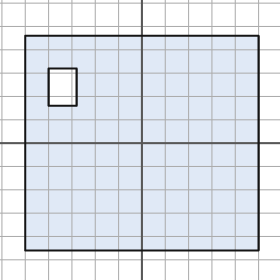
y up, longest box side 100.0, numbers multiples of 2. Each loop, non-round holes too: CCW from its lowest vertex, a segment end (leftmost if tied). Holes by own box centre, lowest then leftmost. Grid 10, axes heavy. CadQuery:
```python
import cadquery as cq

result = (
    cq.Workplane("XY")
    .moveTo(-50.0, -46.0)
    .lineTo(50.0, -46.0)
    .lineTo(50.0, 46.0)
    .lineTo(-50.0, 46.0)
    .close()
    .moveTo(-40.0, 16.0)
    .lineTo(-28.0, 16.0)
    .lineTo(-28.0, 32.0)
    .lineTo(-40.0, 32.0)
    .close()
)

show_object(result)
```